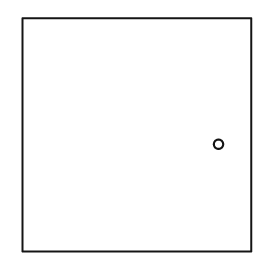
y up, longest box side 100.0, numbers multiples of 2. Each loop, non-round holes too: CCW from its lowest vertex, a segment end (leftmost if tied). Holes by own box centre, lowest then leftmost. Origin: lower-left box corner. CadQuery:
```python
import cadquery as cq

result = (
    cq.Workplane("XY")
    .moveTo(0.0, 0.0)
    .lineTo(98.0, 0.0)
    .lineTo(98.0, 100.0)
    .lineTo(0.0, 100.0)
    .close()
    .moveTo(84.0, 46.0)
    .circle(2.0)
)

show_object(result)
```